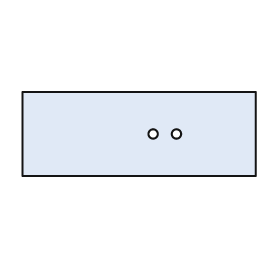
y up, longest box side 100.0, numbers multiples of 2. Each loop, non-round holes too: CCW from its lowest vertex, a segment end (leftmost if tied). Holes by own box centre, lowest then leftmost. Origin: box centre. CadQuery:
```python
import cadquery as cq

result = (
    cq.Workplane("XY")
    .moveTo(-50.0, -18.0)
    .lineTo(50.0, -18.0)
    .lineTo(50.0, 18.0)
    .lineTo(-50.0, 18.0)
    .close()
    .moveTo(6.0, 0.0)
    .circle(2.0)
    .moveTo(16.0, 0.0)
    .circle(2.0)
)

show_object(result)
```